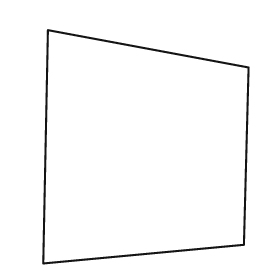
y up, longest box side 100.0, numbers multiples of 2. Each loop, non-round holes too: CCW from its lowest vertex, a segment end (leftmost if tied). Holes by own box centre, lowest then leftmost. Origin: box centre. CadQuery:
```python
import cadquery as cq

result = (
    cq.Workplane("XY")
    .moveTo(-44.0, -50.0)
    .lineTo(42.0, -42.0)
    .lineTo(44.0, 34.0)
    .lineTo(-42.0, 50.0)
    .close()
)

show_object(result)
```